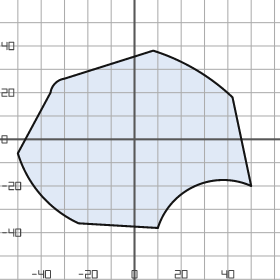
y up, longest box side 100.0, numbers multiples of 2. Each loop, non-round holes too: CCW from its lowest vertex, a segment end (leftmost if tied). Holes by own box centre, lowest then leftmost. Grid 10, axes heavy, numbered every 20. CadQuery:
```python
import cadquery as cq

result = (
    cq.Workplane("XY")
    .moveTo(10.0, -38.0)
    .threePointArc((26.0, -20.0), (50.0, -20.0))
    .lineTo(42.0, 18.0)
    .threePointArc((26.0, 30.0), (8.0, 38.0))
    .lineTo(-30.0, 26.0)
    .threePointArc((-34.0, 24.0), (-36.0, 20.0))
    .lineTo(-50.0, -6.0)
    .threePointArc((-40.0, -24.0), (-24.0, -36.0))
    .close()
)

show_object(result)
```